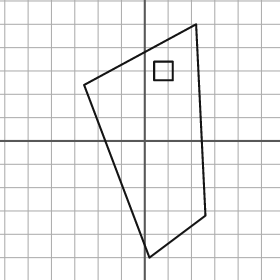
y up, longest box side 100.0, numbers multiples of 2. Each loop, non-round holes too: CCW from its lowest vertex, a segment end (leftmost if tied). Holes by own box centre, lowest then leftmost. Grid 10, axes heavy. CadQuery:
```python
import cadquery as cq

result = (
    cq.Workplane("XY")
    .moveTo(2.0, -50.0)
    .lineTo(26.0, -32.0)
    .lineTo(22.0, 50.0)
    .lineTo(-26.0, 24.0)
    .close()
    .moveTo(4.0, 26.0)
    .lineTo(12.0, 26.0)
    .lineTo(12.0, 34.0)
    .lineTo(4.0, 34.0)
    .close()
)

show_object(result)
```